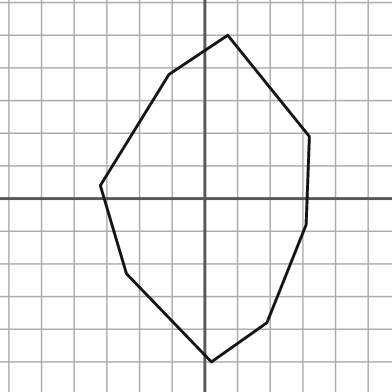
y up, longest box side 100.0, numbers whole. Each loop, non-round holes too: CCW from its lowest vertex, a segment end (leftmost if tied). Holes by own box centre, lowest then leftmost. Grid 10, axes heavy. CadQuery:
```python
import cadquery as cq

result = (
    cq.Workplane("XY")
    .moveTo(2.0, -50.0)
    .lineTo(19.0, -38.0)
    .lineTo(31.0, -8.0)
    .lineTo(32.0, 19.0)
    .lineTo(7.0, 50.0)
    .lineTo(-11.0, 38.0)
    .lineTo(-32.0, 4.0)
    .lineTo(-24.0, -23.0)
    .close()
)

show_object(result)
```